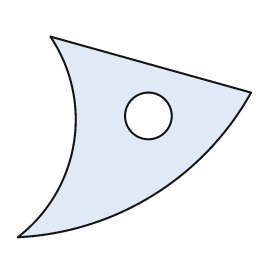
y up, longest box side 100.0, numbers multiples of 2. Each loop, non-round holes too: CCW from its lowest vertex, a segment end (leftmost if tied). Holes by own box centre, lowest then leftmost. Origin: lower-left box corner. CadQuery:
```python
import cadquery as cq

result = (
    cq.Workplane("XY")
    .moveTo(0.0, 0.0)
    .threePointArc((58.0, 18.0), (100.0, 62.0))
    .lineTo(14.0, 86.0)
    .threePointArc((24.0, 40.0), (0.0, 0.0))
    .close()
    .moveTo(56.0, 52.0)
    .circle(10.0)
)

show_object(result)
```